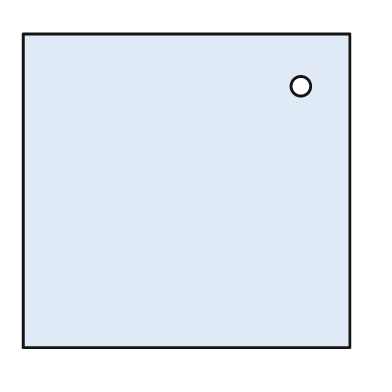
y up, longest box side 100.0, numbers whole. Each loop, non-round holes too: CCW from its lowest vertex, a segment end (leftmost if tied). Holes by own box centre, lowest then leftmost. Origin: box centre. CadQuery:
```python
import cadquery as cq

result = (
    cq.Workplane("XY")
    .moveTo(-50.0, -48.0)
    .lineTo(50.0, -48.0)
    .lineTo(50.0, 48.0)
    .lineTo(-50.0, 48.0)
    .close()
    .moveTo(35.0, 32.0)
    .circle(3.0)
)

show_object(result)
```